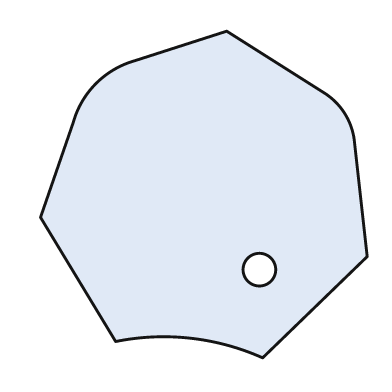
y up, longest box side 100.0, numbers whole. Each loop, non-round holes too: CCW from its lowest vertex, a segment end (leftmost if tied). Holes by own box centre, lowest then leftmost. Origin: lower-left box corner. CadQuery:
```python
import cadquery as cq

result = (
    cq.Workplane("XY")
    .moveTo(68.0, 0.0)
    .lineTo(100.0, 31.0)
    .lineTo(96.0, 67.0)
    .threePointArc((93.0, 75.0), (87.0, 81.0))
    .lineTo(57.0, 100.0)
    .lineTo(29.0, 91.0)
    .threePointArc((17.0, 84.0), (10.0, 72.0))
    .lineTo(0.0, 43.0)
    .lineTo(23.0, 5.0)
    .threePointArc((46.0, 6.0), (68.0, 0.0))
    .close()
    .moveTo(67.0, 27.0)
    .circle(5.0)
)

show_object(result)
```